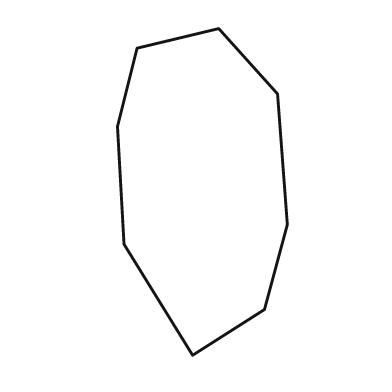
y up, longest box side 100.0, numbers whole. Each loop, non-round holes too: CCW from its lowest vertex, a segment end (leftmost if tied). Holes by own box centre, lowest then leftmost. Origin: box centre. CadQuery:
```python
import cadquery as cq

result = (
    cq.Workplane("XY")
    .moveTo(-3.0, -50.0)
    .lineTo(19.0, -36.0)
    .lineTo(26.0, -10.0)
    .lineTo(23.0, 30.0)
    .lineTo(5.0, 50.0)
    .lineTo(-20.0, 44.0)
    .lineTo(-26.0, 20.0)
    .lineTo(-24.0, -16.0)
    .close()
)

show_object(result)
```